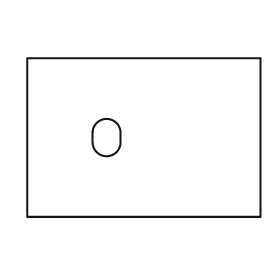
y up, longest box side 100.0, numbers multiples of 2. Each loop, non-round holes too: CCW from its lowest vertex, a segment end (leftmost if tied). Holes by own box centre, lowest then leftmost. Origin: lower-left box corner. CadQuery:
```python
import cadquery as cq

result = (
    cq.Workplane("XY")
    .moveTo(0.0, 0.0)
    .lineTo(100.0, 0.0)
    .lineTo(100.0, 68.0)
    .lineTo(0.0, 68.0)
    .close()
    .moveTo(28.0, 32.0)
    .threePointArc((34.0, 26.0), (40.0, 32.0))
    .lineTo(40.0, 36.0)
    .threePointArc((34.0, 42.0), (28.0, 36.0))
    .close()
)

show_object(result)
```